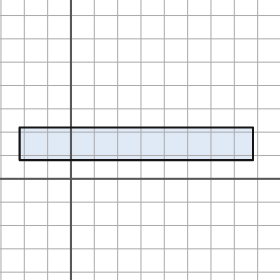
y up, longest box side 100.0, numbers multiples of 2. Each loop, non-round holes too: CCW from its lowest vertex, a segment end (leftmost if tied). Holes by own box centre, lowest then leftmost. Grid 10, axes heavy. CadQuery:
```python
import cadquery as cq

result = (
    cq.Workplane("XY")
    .moveTo(-22.0, 8.0)
    .lineTo(78.0, 8.0)
    .lineTo(78.0, 22.0)
    .lineTo(-22.0, 22.0)
    .close()
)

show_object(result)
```